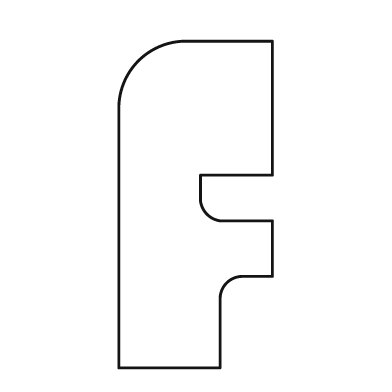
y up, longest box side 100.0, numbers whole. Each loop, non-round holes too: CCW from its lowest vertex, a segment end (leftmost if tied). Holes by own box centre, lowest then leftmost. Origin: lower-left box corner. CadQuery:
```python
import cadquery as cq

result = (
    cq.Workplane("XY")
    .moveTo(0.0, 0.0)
    .lineTo(31.0, 0.0)
    .lineTo(31.0, 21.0)
    .threePointArc((33.0, 26.0), (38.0, 28.0))
    .lineTo(47.0, 28.0)
    .lineTo(47.0, 45.0)
    .lineTo(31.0, 45.0)
    .threePointArc((27.0, 47.0), (25.0, 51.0))
    .lineTo(25.0, 59.0)
    .lineTo(47.0, 59.0)
    .lineTo(47.0, 100.0)
    .lineTo(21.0, 100.0)
    .threePointArc((6.0, 94.0), (0.0, 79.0))
    .close()
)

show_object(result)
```